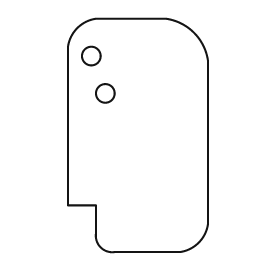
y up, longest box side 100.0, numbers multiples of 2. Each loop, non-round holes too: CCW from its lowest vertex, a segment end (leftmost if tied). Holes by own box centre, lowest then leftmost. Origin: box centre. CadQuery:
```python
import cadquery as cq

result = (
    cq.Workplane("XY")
    .moveTo(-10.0, -50.0)
    .lineTo(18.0, -50.0)
    .threePointArc((26.0, -46.0), (30.0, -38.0))
    .lineTo(30.0, 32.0)
    .threePointArc((24.0, 44.0), (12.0, 50.0))
    .lineTo(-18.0, 50.0)
    .threePointArc((-26.0, 46.0), (-30.0, 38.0))
    .lineTo(-30.0, -30.0)
    .lineTo(-18.0, -30.0)
    .lineTo(-18.0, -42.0)
    .threePointArc((-16.0, -48.0), (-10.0, -50.0))
    .close()
    .moveTo(-14.0, 18.0)
    .circle(4.0)
    .moveTo(-20.0, 34.0)
    .circle(4.0)
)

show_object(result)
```